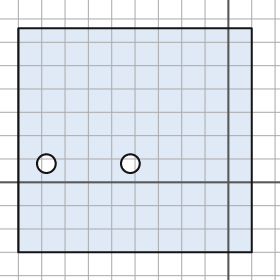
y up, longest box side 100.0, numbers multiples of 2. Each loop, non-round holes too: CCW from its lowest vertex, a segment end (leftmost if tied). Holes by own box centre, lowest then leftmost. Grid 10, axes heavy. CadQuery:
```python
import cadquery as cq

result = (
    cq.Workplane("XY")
    .moveTo(-90.0, -30.0)
    .lineTo(10.0, -30.0)
    .lineTo(10.0, 66.0)
    .lineTo(-90.0, 66.0)
    .close()
    .moveTo(-78.0, 8.0)
    .circle(4.0)
    .moveTo(-42.0, 8.0)
    .circle(4.0)
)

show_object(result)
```